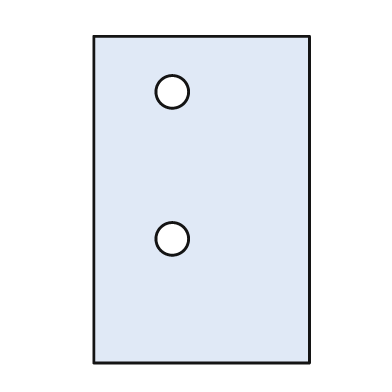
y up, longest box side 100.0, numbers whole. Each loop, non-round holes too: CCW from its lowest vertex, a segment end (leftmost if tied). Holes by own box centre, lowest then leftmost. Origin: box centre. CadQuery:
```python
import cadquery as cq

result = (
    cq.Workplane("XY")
    .moveTo(-33.0, -50.0)
    .lineTo(33.0, -50.0)
    .lineTo(33.0, 50.0)
    .lineTo(-33.0, 50.0)
    .close()
    .moveTo(-9.0, -12.0)
    .circle(5.0)
    .moveTo(-9.0, 33.0)
    .circle(5.0)
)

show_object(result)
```